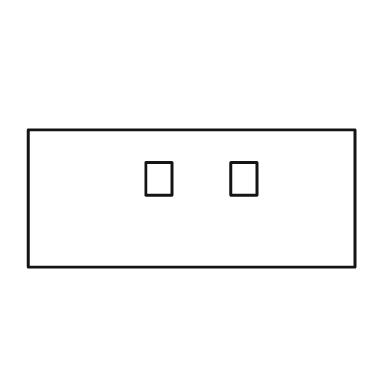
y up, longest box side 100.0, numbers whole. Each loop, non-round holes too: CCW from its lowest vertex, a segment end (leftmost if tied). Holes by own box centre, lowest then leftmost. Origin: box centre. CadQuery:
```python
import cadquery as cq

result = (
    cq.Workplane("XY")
    .moveTo(-50.0, -21.0)
    .lineTo(50.0, -21.0)
    .lineTo(50.0, 21.0)
    .lineTo(-50.0, 21.0)
    .close()
    .moveTo(-14.0, 1.0)
    .lineTo(-6.0, 1.0)
    .lineTo(-6.0, 11.0)
    .lineTo(-14.0, 11.0)
    .close()
    .moveTo(12.0, 1.0)
    .lineTo(20.0, 1.0)
    .lineTo(20.0, 11.0)
    .lineTo(12.0, 11.0)
    .close()
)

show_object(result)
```